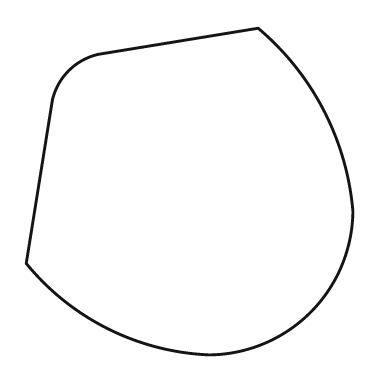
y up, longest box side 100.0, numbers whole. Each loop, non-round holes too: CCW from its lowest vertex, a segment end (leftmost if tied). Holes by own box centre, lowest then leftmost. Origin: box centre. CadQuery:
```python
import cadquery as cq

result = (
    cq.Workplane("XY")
    .moveTo(6.0, -50.0)
    .threePointArc((37.0, -37.0), (50.0, -6.0))
    .threePointArc((41.0, 25.0), (21.0, 50.0))
    .lineTo(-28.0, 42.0)
    .threePointArc((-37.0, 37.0), (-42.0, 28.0))
    .lineTo(-50.0, -22.0)
    .threePointArc((-25.0, -42.0), (6.0, -50.0))
    .close()
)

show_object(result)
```